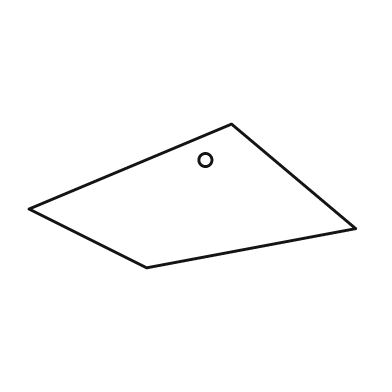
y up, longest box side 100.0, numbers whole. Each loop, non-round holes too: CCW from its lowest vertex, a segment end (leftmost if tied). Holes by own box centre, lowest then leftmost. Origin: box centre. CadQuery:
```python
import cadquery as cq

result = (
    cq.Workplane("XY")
    .moveTo(-14.0, -22.0)
    .lineTo(50.0, -10.0)
    .lineTo(12.0, 22.0)
    .lineTo(-50.0, -4.0)
    .close()
    .moveTo(4.0, 11.0)
    .circle(2.0)
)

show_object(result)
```